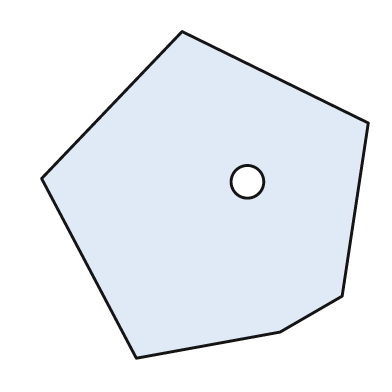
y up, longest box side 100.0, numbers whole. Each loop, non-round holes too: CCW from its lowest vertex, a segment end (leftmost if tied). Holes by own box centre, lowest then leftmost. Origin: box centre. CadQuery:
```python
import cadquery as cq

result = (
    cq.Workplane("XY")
    .moveTo(-21.0, -50.0)
    .lineTo(23.0, -42.0)
    .lineTo(42.0, -31.0)
    .lineTo(50.0, 22.0)
    .lineTo(-7.0, 50.0)
    .lineTo(-50.0, 5.0)
    .close()
    .moveTo(13.0, 4.0)
    .circle(5.0)
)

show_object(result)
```